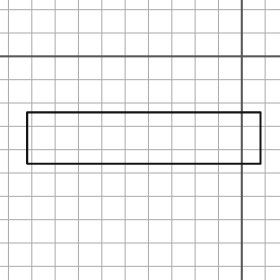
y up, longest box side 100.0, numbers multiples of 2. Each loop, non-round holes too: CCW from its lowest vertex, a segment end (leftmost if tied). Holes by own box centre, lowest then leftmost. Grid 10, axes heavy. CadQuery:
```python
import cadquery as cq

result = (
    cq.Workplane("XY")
    .moveTo(-92.0, -46.0)
    .lineTo(8.0, -46.0)
    .lineTo(8.0, -24.0)
    .lineTo(-92.0, -24.0)
    .close()
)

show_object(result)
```